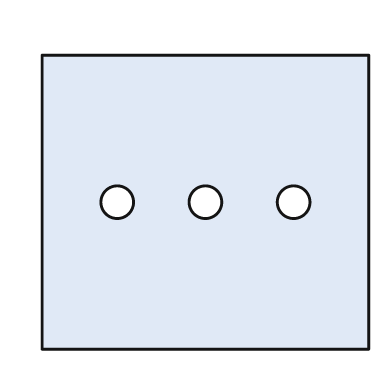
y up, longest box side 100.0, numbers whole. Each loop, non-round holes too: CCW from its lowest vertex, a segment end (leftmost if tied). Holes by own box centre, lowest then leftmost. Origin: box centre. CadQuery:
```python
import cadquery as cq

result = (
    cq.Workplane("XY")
    .moveTo(-50.0, -45.0)
    .lineTo(50.0, -45.0)
    .lineTo(50.0, 45.0)
    .lineTo(-50.0, 45.0)
    .close()
    .moveTo(-27.0, 0.0)
    .circle(5.0)
    .moveTo(0.0, 0.0)
    .circle(5.0)
    .moveTo(27.0, 0.0)
    .circle(5.0)
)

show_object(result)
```